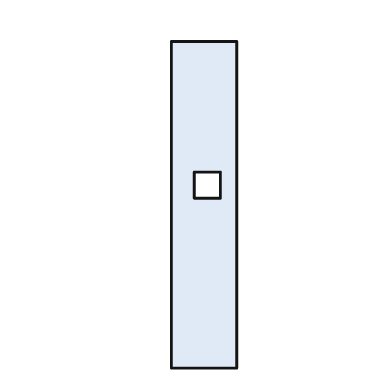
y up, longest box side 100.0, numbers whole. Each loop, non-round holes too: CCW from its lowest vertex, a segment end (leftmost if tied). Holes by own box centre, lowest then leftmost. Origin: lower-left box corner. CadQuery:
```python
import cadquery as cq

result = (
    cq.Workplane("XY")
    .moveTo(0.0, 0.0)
    .lineTo(20.0, 0.0)
    .lineTo(20.0, 100.0)
    .lineTo(0.0, 100.0)
    .close()
    .moveTo(7.0, 52.0)
    .lineTo(15.0, 52.0)
    .lineTo(15.0, 60.0)
    .lineTo(7.0, 60.0)
    .close()
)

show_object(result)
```